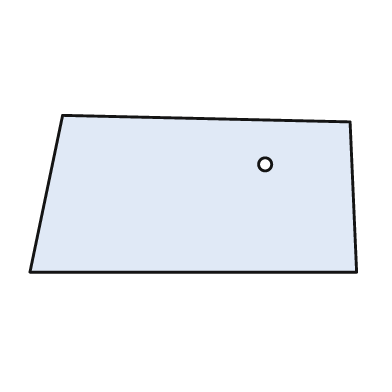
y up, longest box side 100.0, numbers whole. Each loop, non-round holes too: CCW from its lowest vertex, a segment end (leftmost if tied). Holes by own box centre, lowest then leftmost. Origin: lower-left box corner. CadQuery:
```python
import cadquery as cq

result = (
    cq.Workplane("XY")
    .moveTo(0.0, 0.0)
    .lineTo(100.0, 0.0)
    .lineTo(98.0, 46.0)
    .lineTo(10.0, 48.0)
    .close()
    .moveTo(72.0, 33.0)
    .circle(2.0)
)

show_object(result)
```